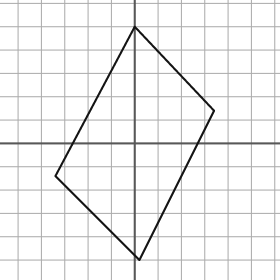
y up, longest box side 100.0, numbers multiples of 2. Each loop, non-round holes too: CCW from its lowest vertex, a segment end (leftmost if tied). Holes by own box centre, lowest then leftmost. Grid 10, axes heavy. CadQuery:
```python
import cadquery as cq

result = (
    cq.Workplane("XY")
    .moveTo(2.0, -50.0)
    .lineTo(34.0, 14.0)
    .lineTo(0.0, 50.0)
    .lineTo(-34.0, -14.0)
    .close()
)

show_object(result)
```